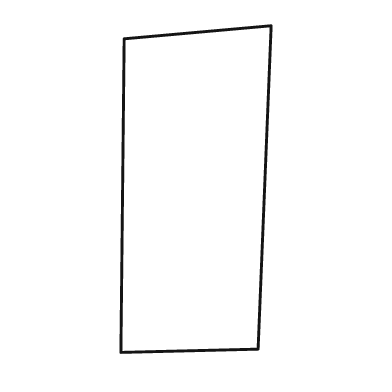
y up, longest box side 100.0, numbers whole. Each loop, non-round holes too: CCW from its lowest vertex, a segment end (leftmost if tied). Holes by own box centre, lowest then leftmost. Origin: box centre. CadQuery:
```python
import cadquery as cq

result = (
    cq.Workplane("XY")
    .moveTo(-23.0, -50.0)
    .lineTo(19.0, -49.0)
    .lineTo(23.0, 50.0)
    .lineTo(-22.0, 46.0)
    .close()
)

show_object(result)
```